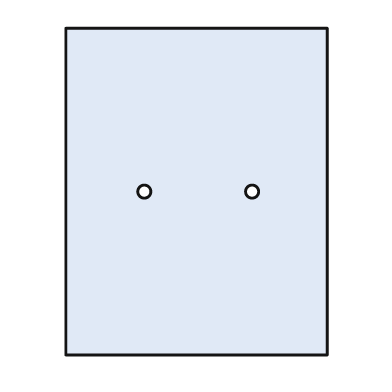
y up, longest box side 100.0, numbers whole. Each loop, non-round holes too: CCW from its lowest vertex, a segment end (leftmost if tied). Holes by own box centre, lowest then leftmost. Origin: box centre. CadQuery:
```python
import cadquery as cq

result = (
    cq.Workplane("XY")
    .moveTo(-40.0, -50.0)
    .lineTo(40.0, -50.0)
    .lineTo(40.0, 50.0)
    .lineTo(-40.0, 50.0)
    .close()
    .moveTo(-16.0, 0.0)
    .circle(2.0)
    .moveTo(17.0, 0.0)
    .circle(2.0)
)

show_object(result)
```